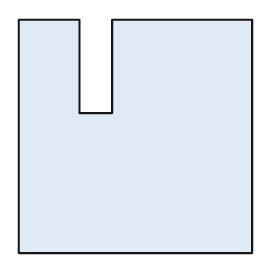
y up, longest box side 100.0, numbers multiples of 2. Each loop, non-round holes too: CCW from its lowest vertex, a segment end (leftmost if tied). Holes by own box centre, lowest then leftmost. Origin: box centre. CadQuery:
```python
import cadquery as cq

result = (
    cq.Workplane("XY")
    .moveTo(-50.0, -50.0)
    .lineTo(50.0, -50.0)
    .lineTo(50.0, 50.0)
    .lineTo(-10.0, 50.0)
    .lineTo(-10.0, 10.0)
    .lineTo(-24.0, 10.0)
    .lineTo(-24.0, 50.0)
    .lineTo(-50.0, 50.0)
    .close()
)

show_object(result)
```